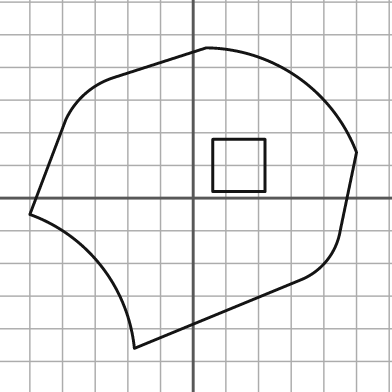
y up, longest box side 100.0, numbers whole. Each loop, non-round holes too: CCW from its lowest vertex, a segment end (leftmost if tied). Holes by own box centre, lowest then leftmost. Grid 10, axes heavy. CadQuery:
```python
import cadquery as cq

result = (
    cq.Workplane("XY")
    .moveTo(-18.0, -46.0)
    .lineTo(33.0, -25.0)
    .threePointArc((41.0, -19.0), (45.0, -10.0))
    .lineTo(50.0, 14.0)
    .threePointArc((32.0, 37.0), (4.0, 46.0))
    .lineTo(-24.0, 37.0)
    .threePointArc((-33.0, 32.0), (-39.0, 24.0))
    .lineTo(-50.0, -5.0)
    .threePointArc((-28.0, -21.0), (-18.0, -46.0))
    .close()
    .moveTo(6.0, 2.0)
    .lineTo(22.0, 2.0)
    .lineTo(22.0, 18.0)
    .lineTo(6.0, 18.0)
    .close()
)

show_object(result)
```